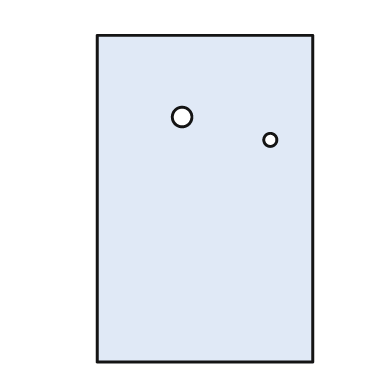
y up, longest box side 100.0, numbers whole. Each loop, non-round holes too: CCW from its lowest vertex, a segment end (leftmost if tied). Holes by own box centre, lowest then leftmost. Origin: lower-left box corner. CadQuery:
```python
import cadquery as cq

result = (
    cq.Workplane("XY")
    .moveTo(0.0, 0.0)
    .lineTo(66.0, 0.0)
    .lineTo(66.0, 100.0)
    .lineTo(0.0, 100.0)
    .close()
    .moveTo(53.0, 68.0)
    .circle(2.0)
    .moveTo(26.0, 75.0)
    .circle(3.0)
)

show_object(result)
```